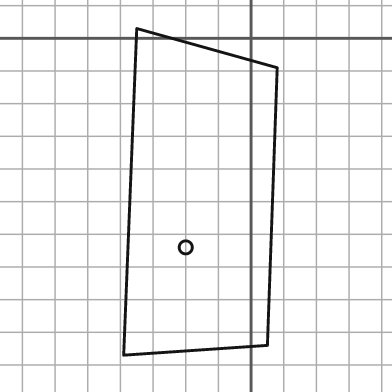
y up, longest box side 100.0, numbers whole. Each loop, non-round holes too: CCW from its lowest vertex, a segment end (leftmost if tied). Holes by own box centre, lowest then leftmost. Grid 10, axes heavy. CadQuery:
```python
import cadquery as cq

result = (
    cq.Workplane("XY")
    .moveTo(-39.0, -97.0)
    .lineTo(5.0, -94.0)
    .lineTo(8.0, -9.0)
    .lineTo(-35.0, 3.0)
    .close()
    .moveTo(-20.0, -64.0)
    .circle(2.0)
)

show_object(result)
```